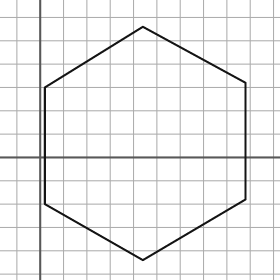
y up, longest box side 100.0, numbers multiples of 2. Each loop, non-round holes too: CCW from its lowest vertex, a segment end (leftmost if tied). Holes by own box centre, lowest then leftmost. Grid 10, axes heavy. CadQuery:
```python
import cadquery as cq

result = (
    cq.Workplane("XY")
    .moveTo(44.0, -44.0)
    .lineTo(88.0, -18.0)
    .lineTo(88.0, 32.0)
    .lineTo(44.0, 56.0)
    .lineTo(2.0, 30.0)
    .lineTo(2.0, -20.0)
    .close()
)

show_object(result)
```